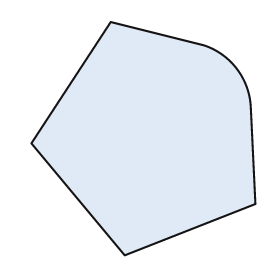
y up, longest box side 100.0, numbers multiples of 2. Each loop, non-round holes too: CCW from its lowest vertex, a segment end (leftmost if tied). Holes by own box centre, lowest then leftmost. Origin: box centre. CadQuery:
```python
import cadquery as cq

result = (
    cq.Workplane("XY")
    .moveTo(-8.0, -50.0)
    .lineTo(48.0, -28.0)
    .lineTo(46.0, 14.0)
    .threePointArc((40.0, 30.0), (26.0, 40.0))
    .lineTo(-14.0, 50.0)
    .lineTo(-48.0, -2.0)
    .close()
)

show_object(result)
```